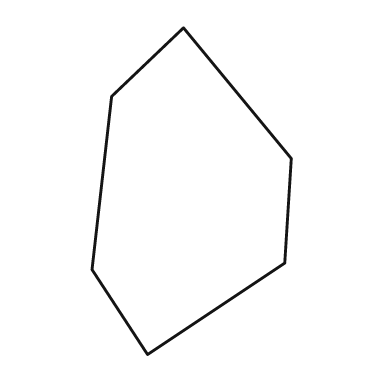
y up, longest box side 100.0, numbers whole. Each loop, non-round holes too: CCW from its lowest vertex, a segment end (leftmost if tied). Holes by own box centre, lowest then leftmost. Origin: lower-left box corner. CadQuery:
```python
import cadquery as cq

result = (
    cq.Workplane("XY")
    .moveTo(17.0, 0.0)
    .lineTo(59.0, 28.0)
    .lineTo(61.0, 60.0)
    .lineTo(28.0, 100.0)
    .lineTo(6.0, 79.0)
    .lineTo(0.0, 26.0)
    .close()
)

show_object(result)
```